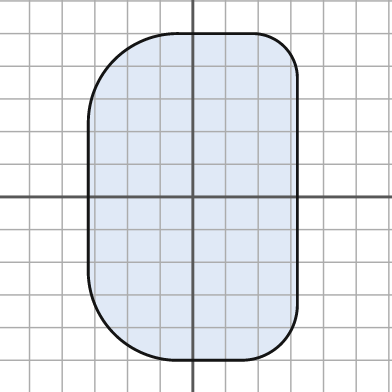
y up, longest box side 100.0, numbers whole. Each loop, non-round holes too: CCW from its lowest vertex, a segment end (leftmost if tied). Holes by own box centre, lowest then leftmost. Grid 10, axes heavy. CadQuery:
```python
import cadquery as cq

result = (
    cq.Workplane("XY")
    .moveTo(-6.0, -50.0)
    .lineTo(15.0, -50.0)
    .threePointArc((27.0, -45.0), (32.0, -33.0))
    .lineTo(32.0, 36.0)
    .threePointArc((28.0, 46.0), (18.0, 50.0))
    .lineTo(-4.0, 50.0)
    .threePointArc((-24.0, 42.0), (-32.0, 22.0))
    .lineTo(-32.0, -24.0)
    .threePointArc((-24.0, -42.0), (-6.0, -50.0))
    .close()
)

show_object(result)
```